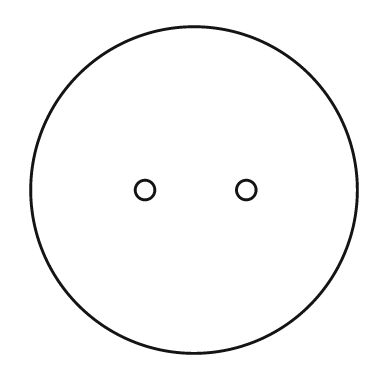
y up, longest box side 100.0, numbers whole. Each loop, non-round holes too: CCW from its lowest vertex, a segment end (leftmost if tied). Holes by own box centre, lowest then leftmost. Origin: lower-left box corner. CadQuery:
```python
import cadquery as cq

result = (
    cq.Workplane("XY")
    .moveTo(50.0, 50.0)
    .circle(50.0)
    .moveTo(35.0, 50.0)
    .circle(3.0)
    .moveTo(66.0, 50.0)
    .circle(3.0)
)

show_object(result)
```